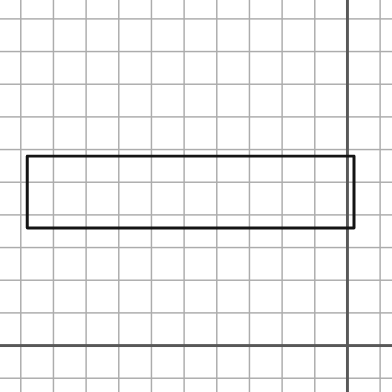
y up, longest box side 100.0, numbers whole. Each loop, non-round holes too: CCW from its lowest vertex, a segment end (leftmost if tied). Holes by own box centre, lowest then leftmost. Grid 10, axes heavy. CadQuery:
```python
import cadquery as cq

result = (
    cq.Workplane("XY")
    .moveTo(-98.0, 36.0)
    .lineTo(2.0, 36.0)
    .lineTo(2.0, 58.0)
    .lineTo(-98.0, 58.0)
    .close()
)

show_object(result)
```